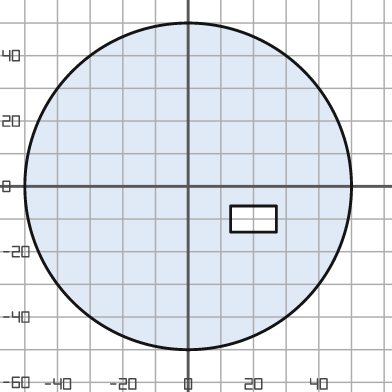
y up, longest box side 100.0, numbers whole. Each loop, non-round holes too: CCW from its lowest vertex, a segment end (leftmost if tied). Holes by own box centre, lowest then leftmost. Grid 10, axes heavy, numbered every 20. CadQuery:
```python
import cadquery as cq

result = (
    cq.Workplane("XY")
    .moveTo(0.0, 0.0)
    .circle(50.0)
    .moveTo(13.0, -14.0)
    .lineTo(27.0, -14.0)
    .lineTo(27.0, -6.0)
    .lineTo(13.0, -6.0)
    .close()
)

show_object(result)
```